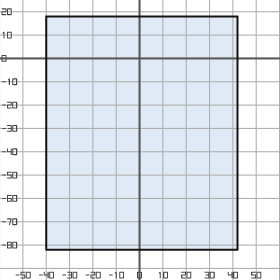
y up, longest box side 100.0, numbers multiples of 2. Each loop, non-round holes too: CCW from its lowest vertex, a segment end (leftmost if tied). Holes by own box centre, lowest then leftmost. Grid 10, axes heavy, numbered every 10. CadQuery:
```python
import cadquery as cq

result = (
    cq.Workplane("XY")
    .moveTo(-40.0, -82.0)
    .lineTo(42.0, -82.0)
    .lineTo(42.0, 18.0)
    .lineTo(-40.0, 18.0)
    .close()
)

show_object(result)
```